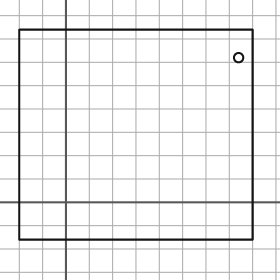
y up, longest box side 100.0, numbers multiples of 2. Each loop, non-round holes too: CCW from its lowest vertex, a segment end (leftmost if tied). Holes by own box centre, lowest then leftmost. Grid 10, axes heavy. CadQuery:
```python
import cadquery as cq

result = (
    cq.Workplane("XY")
    .moveTo(-20.0, -16.0)
    .lineTo(80.0, -16.0)
    .lineTo(80.0, 74.0)
    .lineTo(-20.0, 74.0)
    .close()
    .moveTo(74.0, 62.0)
    .circle(2.0)
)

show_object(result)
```